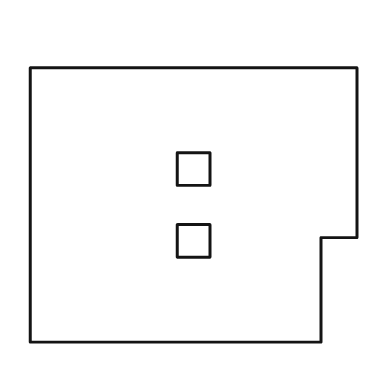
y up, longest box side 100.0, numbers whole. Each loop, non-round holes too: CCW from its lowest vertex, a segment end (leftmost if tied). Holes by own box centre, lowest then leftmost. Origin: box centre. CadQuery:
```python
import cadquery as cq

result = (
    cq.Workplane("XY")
    .moveTo(-50.0, -42.0)
    .lineTo(39.0, -42.0)
    .lineTo(39.0, -10.0)
    .lineTo(50.0, -10.0)
    .lineTo(50.0, 42.0)
    .lineTo(-50.0, 42.0)
    .close()
    .moveTo(-5.0, -16.0)
    .lineTo(5.0, -16.0)
    .lineTo(5.0, -6.0)
    .lineTo(-5.0, -6.0)
    .close()
    .moveTo(-5.0, 6.0)
    .lineTo(5.0, 6.0)
    .lineTo(5.0, 16.0)
    .lineTo(-5.0, 16.0)
    .close()
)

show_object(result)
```